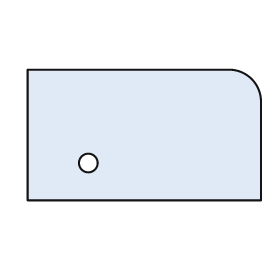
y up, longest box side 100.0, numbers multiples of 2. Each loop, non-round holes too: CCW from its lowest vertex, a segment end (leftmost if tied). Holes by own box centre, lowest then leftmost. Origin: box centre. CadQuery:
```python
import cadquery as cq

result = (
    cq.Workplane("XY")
    .moveTo(-50.0, -28.0)
    .lineTo(50.0, -28.0)
    .lineTo(50.0, 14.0)
    .threePointArc((46.0, 24.0), (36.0, 28.0))
    .lineTo(-50.0, 28.0)
    .close()
    .moveTo(-24.0, -12.0)
    .circle(4.0)
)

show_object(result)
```